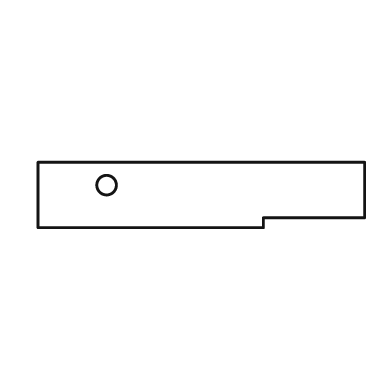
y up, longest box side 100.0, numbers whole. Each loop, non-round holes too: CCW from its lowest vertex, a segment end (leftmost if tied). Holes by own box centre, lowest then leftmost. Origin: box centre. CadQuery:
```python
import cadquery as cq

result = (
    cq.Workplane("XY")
    .moveTo(-50.0, -10.0)
    .lineTo(19.0, -10.0)
    .lineTo(19.0, -7.0)
    .lineTo(50.0, -7.0)
    .lineTo(50.0, 10.0)
    .lineTo(-50.0, 10.0)
    .close()
    .moveTo(-29.0, 3.0)
    .circle(3.0)
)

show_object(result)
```